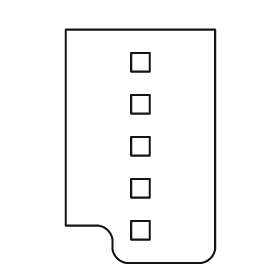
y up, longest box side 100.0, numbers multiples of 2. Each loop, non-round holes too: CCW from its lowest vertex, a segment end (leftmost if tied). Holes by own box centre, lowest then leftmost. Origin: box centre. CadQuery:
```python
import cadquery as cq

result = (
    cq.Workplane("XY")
    .moveTo(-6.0, -50.0)
    .lineTo(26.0, -50.0)
    .threePointArc((30.0, -48.0), (32.0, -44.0))
    .lineTo(32.0, 50.0)
    .lineTo(-32.0, 50.0)
    .lineTo(-32.0, -34.0)
    .lineTo(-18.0, -34.0)
    .threePointArc((-14.0, -36.0), (-12.0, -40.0))
    .lineTo(-12.0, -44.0)
    .threePointArc((-10.0, -48.0), (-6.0, -50.0))
    .close()
    .moveTo(-4.0, -40.0)
    .lineTo(4.0, -40.0)
    .lineTo(4.0, -32.0)
    .lineTo(-4.0, -32.0)
    .close()
    .moveTo(-4.0, -22.0)
    .lineTo(4.0, -22.0)
    .lineTo(4.0, -14.0)
    .lineTo(-4.0, -14.0)
    .close()
    .moveTo(-4.0, -4.0)
    .lineTo(4.0, -4.0)
    .lineTo(4.0, 4.0)
    .lineTo(-4.0, 4.0)
    .close()
    .moveTo(-4.0, 14.0)
    .lineTo(4.0, 14.0)
    .lineTo(4.0, 22.0)
    .lineTo(-4.0, 22.0)
    .close()
    .moveTo(-4.0, 32.0)
    .lineTo(4.0, 32.0)
    .lineTo(4.0, 40.0)
    .lineTo(-4.0, 40.0)
    .close()
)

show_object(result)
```